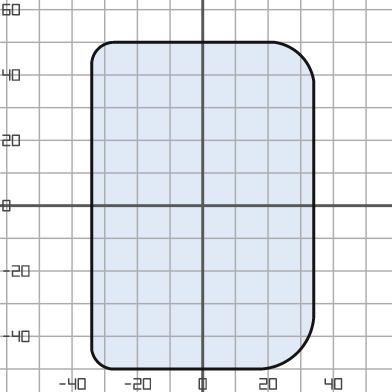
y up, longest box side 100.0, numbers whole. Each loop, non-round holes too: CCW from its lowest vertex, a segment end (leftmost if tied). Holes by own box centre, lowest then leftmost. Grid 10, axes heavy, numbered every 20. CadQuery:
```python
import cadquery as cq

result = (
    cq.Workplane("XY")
    .moveTo(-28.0, -50.0)
    .lineTo(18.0, -50.0)
    .threePointArc((29.0, -45.0), (34.0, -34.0))
    .lineTo(34.0, 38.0)
    .threePointArc((30.0, 46.0), (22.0, 50.0))
    .lineTo(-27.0, 50.0)
    .threePointArc((-32.0, 48.0), (-34.0, 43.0))
    .lineTo(-34.0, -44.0)
    .threePointArc((-32.0, -48.0), (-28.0, -50.0))
    .close()
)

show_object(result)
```